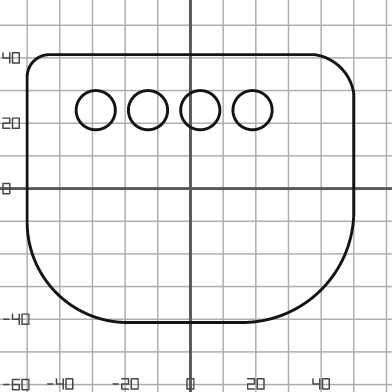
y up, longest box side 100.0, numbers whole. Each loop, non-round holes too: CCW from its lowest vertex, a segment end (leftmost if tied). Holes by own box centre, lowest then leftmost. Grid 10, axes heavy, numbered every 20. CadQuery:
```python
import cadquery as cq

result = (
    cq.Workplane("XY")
    .moveTo(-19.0, -41.0)
    .lineTo(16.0, -41.0)
    .threePointArc((40.0, -31.0), (50.0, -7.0))
    .lineTo(50.0, 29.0)
    .threePointArc((46.0, 37.0), (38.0, 41.0))
    .lineTo(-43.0, 41.0)
    .threePointArc((-48.0, 39.0), (-50.0, 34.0))
    .lineTo(-50.0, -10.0)
    .threePointArc((-41.0, -32.0), (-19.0, -41.0))
    .close()
    .moveTo(-29.0, 24.0)
    .circle(6.0)
    .moveTo(-13.0, 24.0)
    .circle(6.0)
    .moveTo(3.0, 24.0)
    .circle(6.0)
    .moveTo(19.0, 24.0)
    .circle(6.0)
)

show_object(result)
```